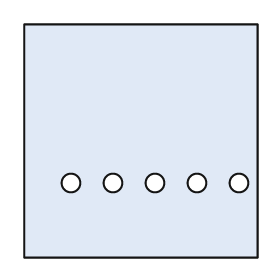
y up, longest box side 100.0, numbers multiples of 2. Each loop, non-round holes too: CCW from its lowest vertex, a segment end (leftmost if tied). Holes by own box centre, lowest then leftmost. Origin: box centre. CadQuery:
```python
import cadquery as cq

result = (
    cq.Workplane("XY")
    .moveTo(-50.0, -50.0)
    .lineTo(50.0, -50.0)
    .lineTo(50.0, 50.0)
    .lineTo(-50.0, 50.0)
    .close()
    .moveTo(-30.0, -18.0)
    .circle(4.0)
    .moveTo(-12.0, -18.0)
    .circle(4.0)
    .moveTo(6.0, -18.0)
    .circle(4.0)
    .moveTo(24.0, -18.0)
    .circle(4.0)
    .moveTo(42.0, -18.0)
    .circle(4.0)
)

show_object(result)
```